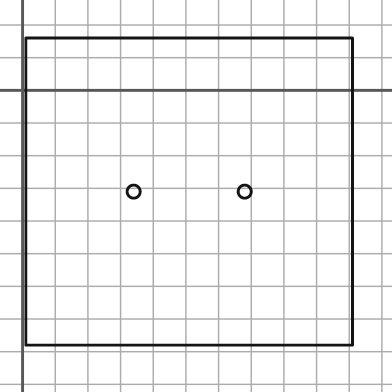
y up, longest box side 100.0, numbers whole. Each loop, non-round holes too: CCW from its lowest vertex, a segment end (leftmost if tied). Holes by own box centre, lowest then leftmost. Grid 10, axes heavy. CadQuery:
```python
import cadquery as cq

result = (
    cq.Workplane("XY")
    .moveTo(1.0, -78.0)
    .lineTo(101.0, -78.0)
    .lineTo(101.0, 16.0)
    .lineTo(1.0, 16.0)
    .close()
    .moveTo(34.0, -31.0)
    .circle(2.0)
    .moveTo(68.0, -31.0)
    .circle(2.0)
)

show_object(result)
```